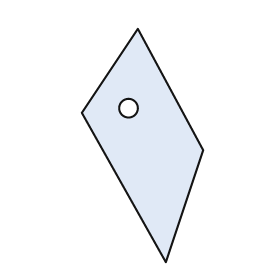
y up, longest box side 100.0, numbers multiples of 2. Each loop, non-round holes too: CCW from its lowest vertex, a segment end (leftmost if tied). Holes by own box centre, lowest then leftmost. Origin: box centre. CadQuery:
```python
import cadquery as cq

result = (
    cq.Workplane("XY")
    .moveTo(10.0, -50.0)
    .lineTo(26.0, -2.0)
    .lineTo(-2.0, 50.0)
    .lineTo(-26.0, 14.0)
    .close()
    .moveTo(-6.0, 16.0)
    .circle(4.0)
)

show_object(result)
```